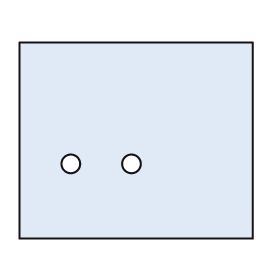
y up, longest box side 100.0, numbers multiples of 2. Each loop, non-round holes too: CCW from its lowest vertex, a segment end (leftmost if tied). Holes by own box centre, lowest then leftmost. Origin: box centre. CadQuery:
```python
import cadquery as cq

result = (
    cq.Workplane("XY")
    .moveTo(-50.0, -42.0)
    .lineTo(50.0, -42.0)
    .lineTo(50.0, 42.0)
    .lineTo(-50.0, 42.0)
    .close()
    .moveTo(-28.0, -10.0)
    .circle(4.0)
    .moveTo(-2.0, -10.0)
    .circle(4.0)
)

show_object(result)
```